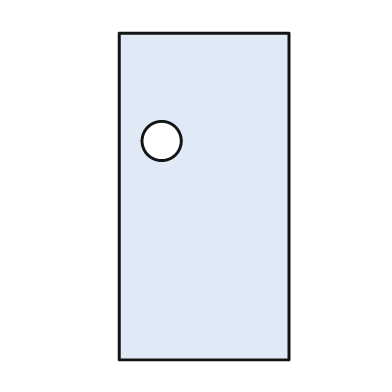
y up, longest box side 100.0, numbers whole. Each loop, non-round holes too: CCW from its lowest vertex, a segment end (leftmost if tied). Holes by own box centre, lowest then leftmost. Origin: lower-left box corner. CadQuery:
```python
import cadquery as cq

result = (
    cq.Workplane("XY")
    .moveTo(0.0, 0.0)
    .lineTo(52.0, 0.0)
    .lineTo(52.0, 100.0)
    .lineTo(0.0, 100.0)
    .close()
    .moveTo(13.0, 67.0)
    .circle(6.0)
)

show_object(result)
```